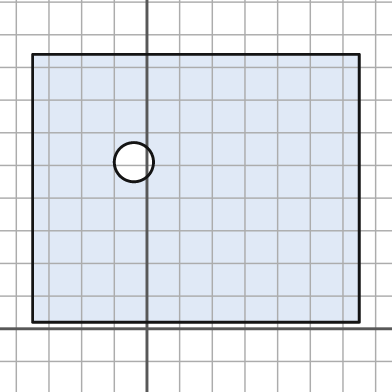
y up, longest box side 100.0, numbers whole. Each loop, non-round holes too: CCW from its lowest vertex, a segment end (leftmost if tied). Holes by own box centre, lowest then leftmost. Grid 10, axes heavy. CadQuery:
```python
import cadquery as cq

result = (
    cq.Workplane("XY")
    .moveTo(-35.0, 2.0)
    .lineTo(65.0, 2.0)
    .lineTo(65.0, 84.0)
    .lineTo(-35.0, 84.0)
    .close()
    .moveTo(-4.0, 51.0)
    .circle(6.0)
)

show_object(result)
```